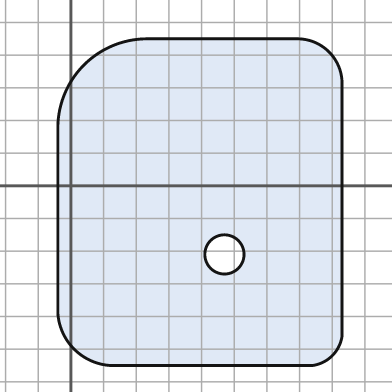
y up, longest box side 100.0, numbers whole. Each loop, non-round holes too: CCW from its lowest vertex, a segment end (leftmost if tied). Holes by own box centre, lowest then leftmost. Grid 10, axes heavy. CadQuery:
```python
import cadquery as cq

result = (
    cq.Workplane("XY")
    .moveTo(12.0, -55.0)
    .lineTo(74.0, -55.0)
    .threePointArc((80.0, -52.0), (83.0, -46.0))
    .lineTo(83.0, 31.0)
    .threePointArc((79.0, 41.0), (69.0, 45.0))
    .lineTo(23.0, 45.0)
    .threePointArc((4.0, 37.0), (-4.0, 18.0))
    .lineTo(-4.0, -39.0)
    .threePointArc((1.0, -50.0), (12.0, -55.0))
    .close()
    .moveTo(47.0, -21.0)
    .circle(6.0)
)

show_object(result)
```